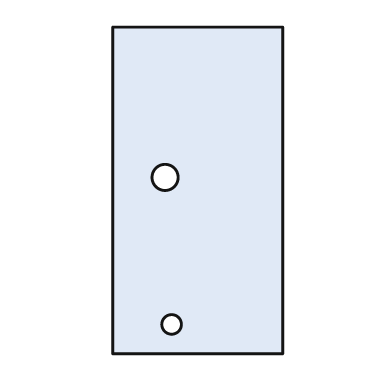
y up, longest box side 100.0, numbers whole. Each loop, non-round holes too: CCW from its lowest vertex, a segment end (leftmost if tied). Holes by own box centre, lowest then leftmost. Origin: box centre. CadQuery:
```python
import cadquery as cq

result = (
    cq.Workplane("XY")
    .moveTo(-26.0, -50.0)
    .lineTo(26.0, -50.0)
    .lineTo(26.0, 50.0)
    .lineTo(-26.0, 50.0)
    .close()
    .moveTo(-8.0, -41.0)
    .circle(3.0)
    .moveTo(-10.0, 4.0)
    .circle(4.0)
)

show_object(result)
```